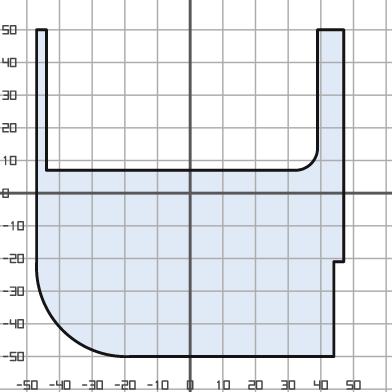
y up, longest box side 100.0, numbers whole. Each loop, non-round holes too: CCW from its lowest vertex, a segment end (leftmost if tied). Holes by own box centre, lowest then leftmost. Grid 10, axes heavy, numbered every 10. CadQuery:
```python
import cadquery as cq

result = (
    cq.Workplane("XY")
    .moveTo(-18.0, -50.0)
    .lineTo(44.0, -50.0)
    .lineTo(44.0, -21.0)
    .lineTo(47.0, -21.0)
    .lineTo(47.0, 50.0)
    .lineTo(39.0, 50.0)
    .lineTo(39.0, 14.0)
    .threePointArc((37.0, 9.0), (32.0, 7.0))
    .lineTo(-44.0, 7.0)
    .lineTo(-44.0, 50.0)
    .lineTo(-47.0, 50.0)
    .lineTo(-47.0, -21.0)
    .threePointArc((-39.0, -42.0), (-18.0, -50.0))
    .close()
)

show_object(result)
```